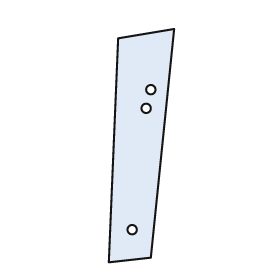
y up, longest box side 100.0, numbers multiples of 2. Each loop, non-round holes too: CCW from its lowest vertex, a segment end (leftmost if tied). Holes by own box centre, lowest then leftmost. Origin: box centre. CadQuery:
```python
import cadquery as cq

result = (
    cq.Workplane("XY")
    .moveTo(-14.0, -50.0)
    .lineTo(4.0, -48.0)
    .lineTo(14.0, 50.0)
    .lineTo(-10.0, 46.0)
    .close()
    .moveTo(-4.0, -36.0)
    .circle(2.0)
    .moveTo(2.0, 16.0)
    .circle(2.0)
    .moveTo(4.0, 24.0)
    .circle(2.0)
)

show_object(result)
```